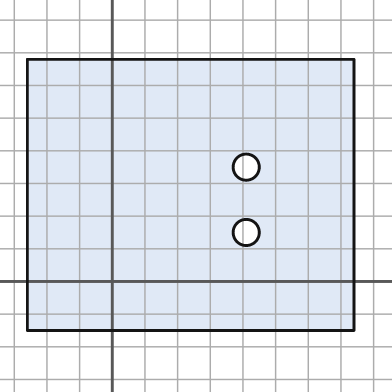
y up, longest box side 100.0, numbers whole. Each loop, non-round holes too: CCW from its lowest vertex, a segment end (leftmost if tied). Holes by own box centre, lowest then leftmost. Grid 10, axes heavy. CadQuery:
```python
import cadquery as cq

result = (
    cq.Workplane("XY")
    .moveTo(-26.0, -15.0)
    .lineTo(74.0, -15.0)
    .lineTo(74.0, 68.0)
    .lineTo(-26.0, 68.0)
    .close()
    .moveTo(41.0, 15.0)
    .circle(4.0)
    .moveTo(41.0, 35.0)
    .circle(4.0)
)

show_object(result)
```